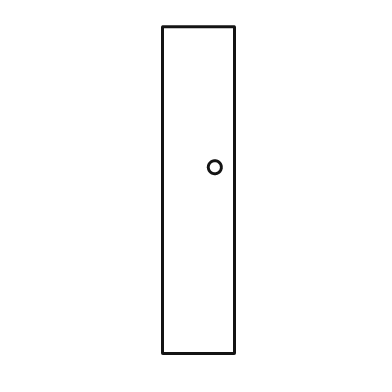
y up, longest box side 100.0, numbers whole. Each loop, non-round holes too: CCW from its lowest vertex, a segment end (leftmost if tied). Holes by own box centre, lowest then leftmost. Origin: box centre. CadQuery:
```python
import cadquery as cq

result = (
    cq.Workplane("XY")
    .moveTo(-11.0, -50.0)
    .lineTo(11.0, -50.0)
    .lineTo(11.0, 50.0)
    .lineTo(-11.0, 50.0)
    .close()
    .moveTo(5.0, 7.0)
    .circle(2.0)
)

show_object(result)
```